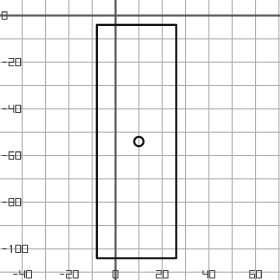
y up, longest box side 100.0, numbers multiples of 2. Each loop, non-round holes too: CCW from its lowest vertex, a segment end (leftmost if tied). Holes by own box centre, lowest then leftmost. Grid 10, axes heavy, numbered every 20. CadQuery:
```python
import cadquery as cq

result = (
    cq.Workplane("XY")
    .moveTo(-8.0, -104.0)
    .lineTo(26.0, -104.0)
    .lineTo(26.0, -4.0)
    .lineTo(-8.0, -4.0)
    .close()
    .moveTo(10.0, -54.0)
    .circle(2.0)
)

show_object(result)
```